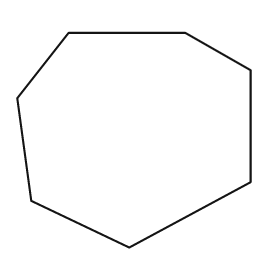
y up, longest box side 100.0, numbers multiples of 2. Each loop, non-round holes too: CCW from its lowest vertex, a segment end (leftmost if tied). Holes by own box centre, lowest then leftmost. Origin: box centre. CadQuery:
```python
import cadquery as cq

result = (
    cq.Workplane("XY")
    .moveTo(-2.0, -46.0)
    .lineTo(50.0, -18.0)
    .lineTo(50.0, 30.0)
    .lineTo(22.0, 46.0)
    .lineTo(-28.0, 46.0)
    .lineTo(-50.0, 18.0)
    .lineTo(-44.0, -26.0)
    .close()
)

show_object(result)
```